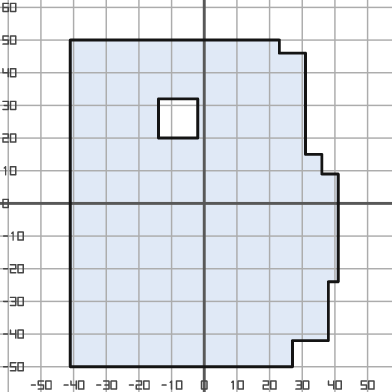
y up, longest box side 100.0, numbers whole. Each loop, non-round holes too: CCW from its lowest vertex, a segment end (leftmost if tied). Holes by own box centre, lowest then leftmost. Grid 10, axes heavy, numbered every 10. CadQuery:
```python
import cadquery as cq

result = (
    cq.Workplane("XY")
    .moveTo(-41.0, -50.0)
    .lineTo(27.0, -50.0)
    .lineTo(27.0, -42.0)
    .lineTo(38.0, -42.0)
    .lineTo(38.0, -24.0)
    .lineTo(41.0, -24.0)
    .lineTo(41.0, 9.0)
    .lineTo(36.0, 9.0)
    .lineTo(36.0, 15.0)
    .lineTo(31.0, 15.0)
    .lineTo(31.0, 46.0)
    .lineTo(23.0, 46.0)
    .lineTo(23.0, 50.0)
    .lineTo(-41.0, 50.0)
    .close()
    .moveTo(-14.0, 20.0)
    .lineTo(-2.0, 20.0)
    .lineTo(-2.0, 32.0)
    .lineTo(-14.0, 32.0)
    .close()
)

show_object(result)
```